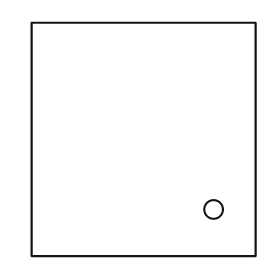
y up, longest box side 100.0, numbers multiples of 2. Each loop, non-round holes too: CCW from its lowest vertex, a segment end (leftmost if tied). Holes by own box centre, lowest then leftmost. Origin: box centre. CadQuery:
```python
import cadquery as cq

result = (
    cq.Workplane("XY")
    .moveTo(-48.0, -50.0)
    .lineTo(48.0, -50.0)
    .lineTo(48.0, 50.0)
    .lineTo(-48.0, 50.0)
    .close()
    .moveTo(30.0, -30.0)
    .circle(4.0)
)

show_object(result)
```